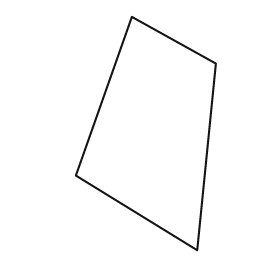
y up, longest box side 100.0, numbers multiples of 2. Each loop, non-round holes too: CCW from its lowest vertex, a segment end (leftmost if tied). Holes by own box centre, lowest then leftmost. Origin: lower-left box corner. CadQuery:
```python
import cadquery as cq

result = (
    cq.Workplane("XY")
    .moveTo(52.0, 0.0)
    .lineTo(60.0, 80.0)
    .lineTo(24.0, 100.0)
    .lineTo(0.0, 32.0)
    .close()
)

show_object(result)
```